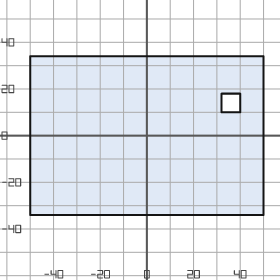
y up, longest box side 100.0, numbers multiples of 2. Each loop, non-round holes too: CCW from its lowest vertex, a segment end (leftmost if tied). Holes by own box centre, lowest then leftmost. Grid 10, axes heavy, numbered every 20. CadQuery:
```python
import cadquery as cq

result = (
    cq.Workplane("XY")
    .moveTo(-50.0, -34.0)
    .lineTo(50.0, -34.0)
    .lineTo(50.0, 34.0)
    .lineTo(-50.0, 34.0)
    .close()
    .moveTo(32.0, 10.0)
    .lineTo(40.0, 10.0)
    .lineTo(40.0, 18.0)
    .lineTo(32.0, 18.0)
    .close()
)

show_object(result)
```